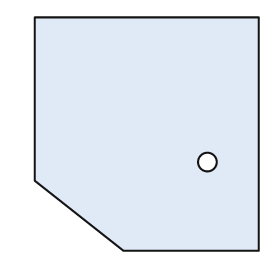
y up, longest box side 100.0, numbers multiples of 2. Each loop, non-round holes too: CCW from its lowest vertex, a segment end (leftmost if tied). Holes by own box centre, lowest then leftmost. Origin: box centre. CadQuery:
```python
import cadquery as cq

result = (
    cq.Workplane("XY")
    .moveTo(-10.0, -50.0)
    .lineTo(48.0, -50.0)
    .lineTo(48.0, 50.0)
    .lineTo(-48.0, 50.0)
    .lineTo(-48.0, -20.0)
    .close()
    .moveTo(26.0, -12.0)
    .circle(4.0)
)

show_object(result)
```